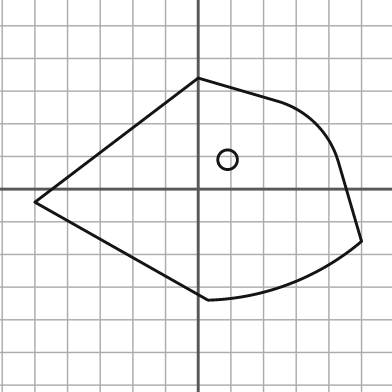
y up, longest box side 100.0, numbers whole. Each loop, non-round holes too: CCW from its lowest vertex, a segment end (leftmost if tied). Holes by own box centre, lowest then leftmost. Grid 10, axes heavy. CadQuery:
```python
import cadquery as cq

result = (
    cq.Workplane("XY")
    .moveTo(3.0, -34.0)
    .threePointArc((28.0, -29.0), (50.0, -16.0))
    .lineTo(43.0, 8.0)
    .threePointArc((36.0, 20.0), (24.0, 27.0))
    .lineTo(0.0, 34.0)
    .lineTo(-50.0, -4.0)
    .close()
    .moveTo(9.0, 9.0)
    .circle(3.0)
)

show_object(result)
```